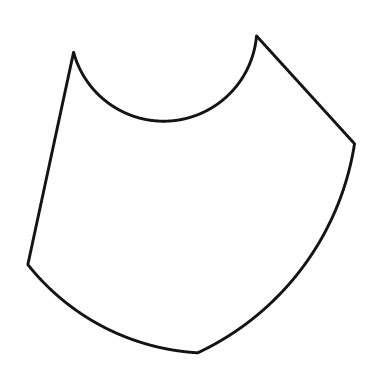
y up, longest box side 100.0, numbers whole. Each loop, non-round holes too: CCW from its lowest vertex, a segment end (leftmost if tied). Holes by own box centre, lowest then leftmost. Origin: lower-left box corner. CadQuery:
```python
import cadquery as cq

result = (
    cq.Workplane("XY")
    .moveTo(52.0, 0.0)
    .threePointArc((84.0, 26.0), (100.0, 64.0))
    .lineTo(70.0, 97.0)
    .threePointArc((44.0, 71.0), (14.0, 92.0))
    .lineTo(0.0, 27.0)
    .threePointArc((23.0, 8.0), (52.0, 0.0))
    .close()
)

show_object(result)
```